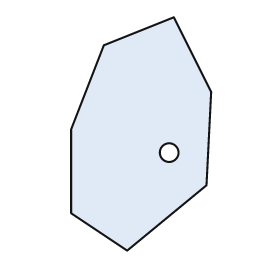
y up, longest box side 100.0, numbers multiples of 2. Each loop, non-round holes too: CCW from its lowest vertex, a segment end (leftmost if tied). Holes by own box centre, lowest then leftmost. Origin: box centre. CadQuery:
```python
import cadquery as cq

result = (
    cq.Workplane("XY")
    .moveTo(-6.0, -50.0)
    .lineTo(28.0, -22.0)
    .lineTo(30.0, 18.0)
    .lineTo(14.0, 50.0)
    .lineTo(-16.0, 38.0)
    .lineTo(-30.0, 2.0)
    .lineTo(-30.0, -34.0)
    .close()
    .moveTo(12.0, -8.0)
    .circle(4.0)
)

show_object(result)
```